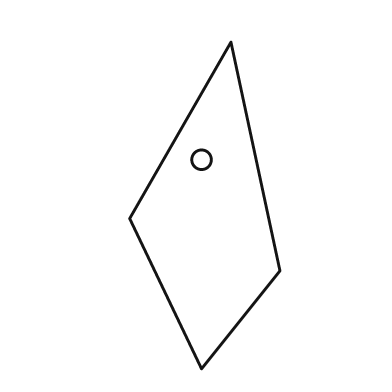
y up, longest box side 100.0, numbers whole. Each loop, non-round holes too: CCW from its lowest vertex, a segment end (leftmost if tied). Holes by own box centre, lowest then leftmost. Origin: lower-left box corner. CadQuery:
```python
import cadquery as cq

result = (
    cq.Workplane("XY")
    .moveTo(22.0, 0.0)
    .lineTo(46.0, 30.0)
    .lineTo(31.0, 100.0)
    .lineTo(0.0, 46.0)
    .close()
    .moveTo(22.0, 64.0)
    .circle(3.0)
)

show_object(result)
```